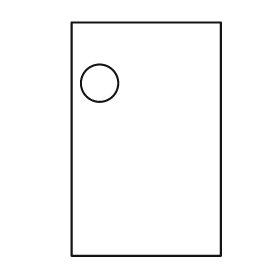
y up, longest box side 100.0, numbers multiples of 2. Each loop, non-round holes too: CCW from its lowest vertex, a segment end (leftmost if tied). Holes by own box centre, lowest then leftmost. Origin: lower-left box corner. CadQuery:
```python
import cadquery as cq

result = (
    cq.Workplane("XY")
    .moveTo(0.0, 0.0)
    .lineTo(64.0, 0.0)
    .lineTo(64.0, 100.0)
    .lineTo(0.0, 100.0)
    .close()
    .moveTo(12.0, 74.0)
    .circle(8.0)
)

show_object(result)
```